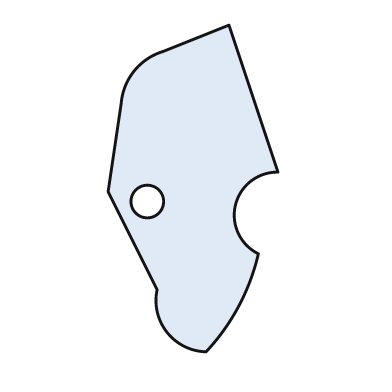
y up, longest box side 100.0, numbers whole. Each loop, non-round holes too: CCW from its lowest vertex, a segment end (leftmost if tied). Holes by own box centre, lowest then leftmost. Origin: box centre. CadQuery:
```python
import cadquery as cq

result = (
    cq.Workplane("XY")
    .moveTo(4.0, -50.0)
    .threePointArc((14.0, -36.0), (20.0, -20.0))
    .threePointArc((13.0, -5.0), (26.0, 5.0))
    .lineTo(11.0, 50.0)
    .lineTo(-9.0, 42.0)
    .threePointArc((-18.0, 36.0), (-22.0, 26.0))
    .lineTo(-26.0, -1.0)
    .lineTo(-11.0, -31.0)
    .threePointArc((-8.0, -44.0), (4.0, -50.0))
    .close()
    .moveTo(-14.0, -4.0)
    .circle(5.0)
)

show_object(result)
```